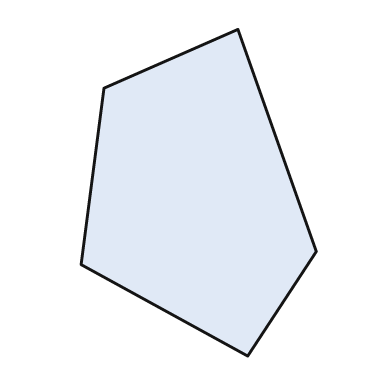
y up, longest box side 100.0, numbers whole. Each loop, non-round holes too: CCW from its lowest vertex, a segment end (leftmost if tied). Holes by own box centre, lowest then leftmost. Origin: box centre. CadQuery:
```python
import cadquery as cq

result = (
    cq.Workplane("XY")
    .moveTo(15.0, -50.0)
    .lineTo(36.0, -18.0)
    .lineTo(12.0, 50.0)
    .lineTo(-29.0, 32.0)
    .lineTo(-36.0, -22.0)
    .close()
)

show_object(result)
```